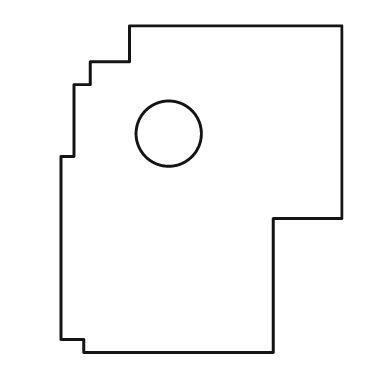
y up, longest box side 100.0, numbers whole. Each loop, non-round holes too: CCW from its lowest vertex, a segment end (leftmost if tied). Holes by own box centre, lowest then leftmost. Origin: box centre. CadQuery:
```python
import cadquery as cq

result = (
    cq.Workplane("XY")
    .moveTo(-36.0, -50.0)
    .lineTo(22.0, -50.0)
    .lineTo(22.0, -9.0)
    .lineTo(43.0, -9.0)
    .lineTo(43.0, 50.0)
    .lineTo(-22.0, 50.0)
    .lineTo(-22.0, 39.0)
    .lineTo(-34.0, 39.0)
    .lineTo(-34.0, 32.0)
    .lineTo(-39.0, 32.0)
    .lineTo(-39.0, 10.0)
    .lineTo(-43.0, 10.0)
    .lineTo(-43.0, -46.0)
    .lineTo(-36.0, -46.0)
    .close()
    .moveTo(-10.0, 17.0)
    .circle(10.0)
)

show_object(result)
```